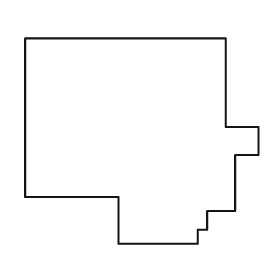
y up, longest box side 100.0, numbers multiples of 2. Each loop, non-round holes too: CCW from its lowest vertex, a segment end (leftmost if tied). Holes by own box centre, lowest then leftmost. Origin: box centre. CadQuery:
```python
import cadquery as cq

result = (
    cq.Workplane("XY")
    .moveTo(-10.0, -44.0)
    .lineTo(24.0, -44.0)
    .lineTo(24.0, -38.0)
    .lineTo(28.0, -38.0)
    .lineTo(28.0, -30.0)
    .lineTo(40.0, -30.0)
    .lineTo(40.0, -6.0)
    .lineTo(50.0, -6.0)
    .lineTo(50.0, 6.0)
    .lineTo(36.0, 6.0)
    .lineTo(36.0, 44.0)
    .lineTo(-50.0, 44.0)
    .lineTo(-50.0, -24.0)
    .lineTo(-10.0, -24.0)
    .close()
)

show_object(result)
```